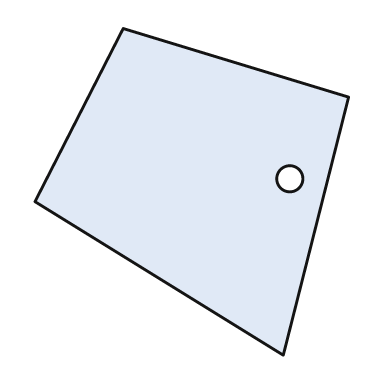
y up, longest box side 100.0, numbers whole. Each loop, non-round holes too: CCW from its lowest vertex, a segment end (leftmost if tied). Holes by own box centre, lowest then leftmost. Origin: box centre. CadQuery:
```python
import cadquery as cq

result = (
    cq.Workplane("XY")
    .moveTo(28.0, -50.0)
    .lineTo(48.0, 29.0)
    .lineTo(-21.0, 50.0)
    .lineTo(-48.0, -3.0)
    .close()
    .moveTo(30.0, 4.0)
    .circle(4.0)
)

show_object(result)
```